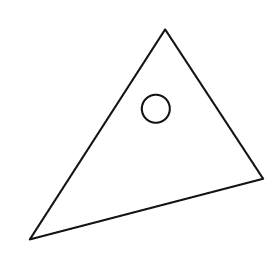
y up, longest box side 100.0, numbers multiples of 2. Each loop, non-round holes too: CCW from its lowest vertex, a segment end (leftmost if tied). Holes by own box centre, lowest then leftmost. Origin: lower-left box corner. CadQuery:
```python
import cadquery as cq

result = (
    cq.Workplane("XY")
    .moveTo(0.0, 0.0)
    .lineTo(100.0, 26.0)
    .lineTo(58.0, 90.0)
    .close()
    .moveTo(54.0, 56.0)
    .circle(6.0)
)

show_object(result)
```